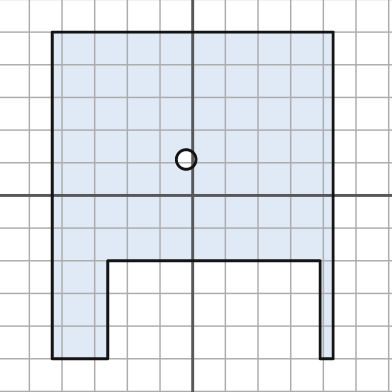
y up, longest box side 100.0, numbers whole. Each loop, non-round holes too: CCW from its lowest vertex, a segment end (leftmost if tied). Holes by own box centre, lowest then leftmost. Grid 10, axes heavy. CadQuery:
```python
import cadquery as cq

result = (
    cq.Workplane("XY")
    .moveTo(-43.0, -50.0)
    .lineTo(-26.0, -50.0)
    .lineTo(-26.0, -20.0)
    .lineTo(39.0, -20.0)
    .lineTo(39.0, -50.0)
    .lineTo(43.0, -50.0)
    .lineTo(43.0, 50.0)
    .lineTo(-43.0, 50.0)
    .close()
    .moveTo(-2.0, 11.0)
    .circle(3.0)
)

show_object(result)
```